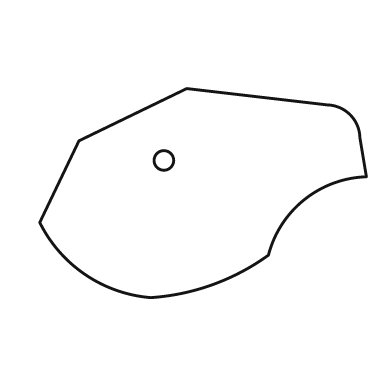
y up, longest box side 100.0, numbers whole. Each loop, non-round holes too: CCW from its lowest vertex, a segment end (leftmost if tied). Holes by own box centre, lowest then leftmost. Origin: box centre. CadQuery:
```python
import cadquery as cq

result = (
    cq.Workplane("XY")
    .moveTo(-16.0, -32.0)
    .threePointArc((3.0, -28.0), (20.0, -19.0))
    .threePointArc((31.0, -2.0), (50.0, 5.0))
    .lineTo(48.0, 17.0)
    .threePointArc((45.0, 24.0), (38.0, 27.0))
    .lineTo(-5.0, 32.0)
    .lineTo(-38.0, 16.0)
    .lineTo(-50.0, -9.0)
    .threePointArc((-36.0, -25.0), (-16.0, -32.0))
    .close()
    .moveTo(-12.0, 10.0)
    .circle(3.0)
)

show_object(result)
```